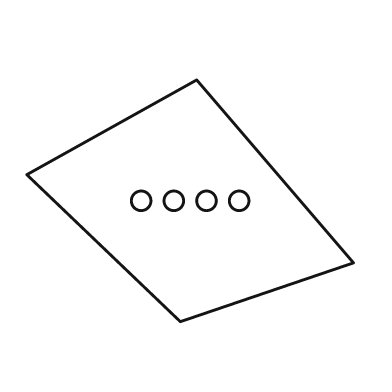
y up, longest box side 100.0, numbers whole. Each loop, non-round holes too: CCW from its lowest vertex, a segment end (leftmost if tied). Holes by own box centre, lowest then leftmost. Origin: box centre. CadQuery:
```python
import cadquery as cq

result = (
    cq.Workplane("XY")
    .moveTo(-3.0, -37.0)
    .lineTo(50.0, -19.0)
    .lineTo(2.0, 37.0)
    .lineTo(-50.0, 8.0)
    .close()
    .moveTo(-15.0, 0.0)
    .circle(3.0)
    .moveTo(-5.0, 0.0)
    .circle(3.0)
    .moveTo(5.0, 0.0)
    .circle(3.0)
    .moveTo(15.0, 0.0)
    .circle(3.0)
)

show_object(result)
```